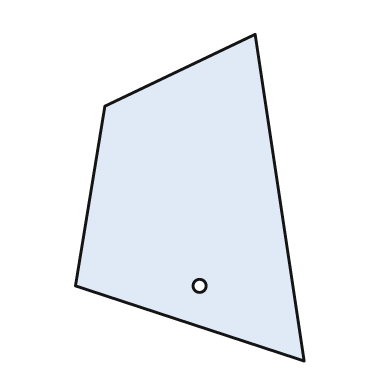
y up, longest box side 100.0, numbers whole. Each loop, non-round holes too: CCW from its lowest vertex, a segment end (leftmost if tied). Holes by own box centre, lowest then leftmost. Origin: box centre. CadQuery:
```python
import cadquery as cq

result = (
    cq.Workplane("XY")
    .moveTo(35.0, -50.0)
    .lineTo(20.0, 50.0)
    .lineTo(-26.0, 28.0)
    .lineTo(-35.0, -27.0)
    .close()
    .moveTo(3.0, -27.0)
    .circle(2.0)
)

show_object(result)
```